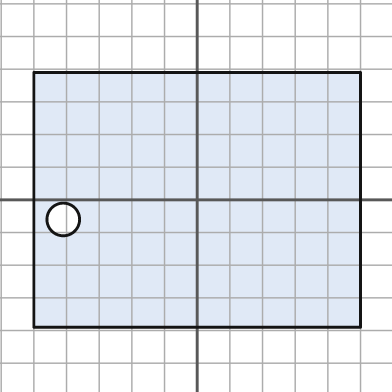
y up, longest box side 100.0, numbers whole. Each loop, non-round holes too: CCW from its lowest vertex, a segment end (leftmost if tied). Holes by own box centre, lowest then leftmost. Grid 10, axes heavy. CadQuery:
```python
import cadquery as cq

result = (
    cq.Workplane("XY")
    .moveTo(-50.0, -39.0)
    .lineTo(50.0, -39.0)
    .lineTo(50.0, 39.0)
    .lineTo(-50.0, 39.0)
    .close()
    .moveTo(-41.0, -6.0)
    .circle(5.0)
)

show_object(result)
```